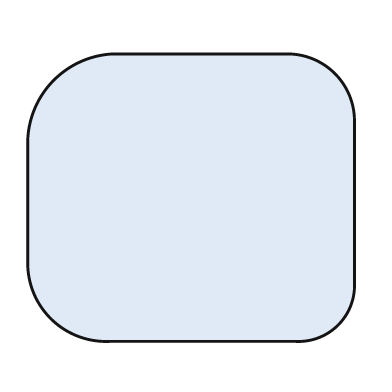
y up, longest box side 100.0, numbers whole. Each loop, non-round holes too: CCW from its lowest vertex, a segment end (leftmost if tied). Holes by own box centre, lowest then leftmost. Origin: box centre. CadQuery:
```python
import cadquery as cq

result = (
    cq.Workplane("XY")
    .moveTo(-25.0, -44.0)
    .lineTo(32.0, -44.0)
    .threePointArc((45.0, -39.0), (50.0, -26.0))
    .lineTo(50.0, 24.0)
    .threePointArc((44.0, 38.0), (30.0, 44.0))
    .lineTo(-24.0, 44.0)
    .threePointArc((-42.0, 36.0), (-50.0, 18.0))
    .lineTo(-50.0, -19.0)
    .threePointArc((-43.0, -37.0), (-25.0, -44.0))
    .close()
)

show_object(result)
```